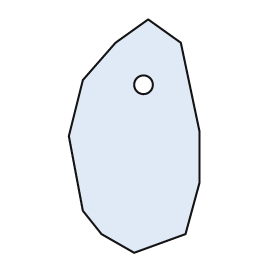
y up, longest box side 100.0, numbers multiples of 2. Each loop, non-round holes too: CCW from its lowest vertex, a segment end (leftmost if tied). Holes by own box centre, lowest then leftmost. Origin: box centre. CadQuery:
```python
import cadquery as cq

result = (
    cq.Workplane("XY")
    .moveTo(0.0, -50.0)
    .lineTo(22.0, -42.0)
    .lineTo(28.0, -20.0)
    .lineTo(28.0, 2.0)
    .lineTo(20.0, 40.0)
    .lineTo(6.0, 50.0)
    .lineTo(-8.0, 40.0)
    .lineTo(-22.0, 24.0)
    .lineTo(-28.0, 0.0)
    .lineTo(-22.0, -32.0)
    .lineTo(-14.0, -42.0)
    .close()
    .moveTo(4.0, 22.0)
    .circle(4.0)
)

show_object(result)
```